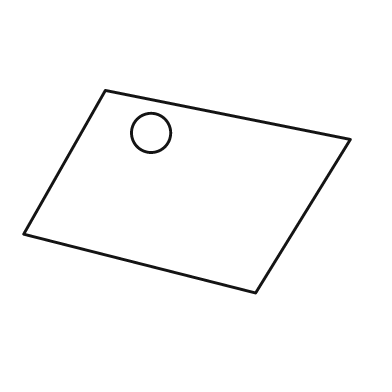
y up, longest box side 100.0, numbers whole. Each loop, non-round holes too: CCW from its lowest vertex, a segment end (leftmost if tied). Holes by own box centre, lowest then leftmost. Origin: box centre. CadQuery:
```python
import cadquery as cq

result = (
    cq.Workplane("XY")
    .moveTo(21.0, -31.0)
    .lineTo(50.0, 16.0)
    .lineTo(-25.0, 31.0)
    .lineTo(-50.0, -13.0)
    .close()
    .moveTo(-11.0, 18.0)
    .circle(6.0)
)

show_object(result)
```